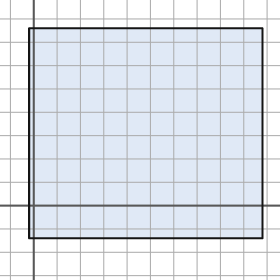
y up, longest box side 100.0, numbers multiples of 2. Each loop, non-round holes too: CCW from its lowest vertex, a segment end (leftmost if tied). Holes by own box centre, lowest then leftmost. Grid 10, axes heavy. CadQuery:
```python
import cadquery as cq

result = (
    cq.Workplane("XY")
    .moveTo(-2.0, -14.0)
    .lineTo(98.0, -14.0)
    .lineTo(98.0, 76.0)
    .lineTo(-2.0, 76.0)
    .close()
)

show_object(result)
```